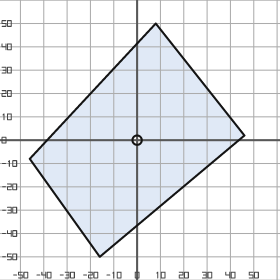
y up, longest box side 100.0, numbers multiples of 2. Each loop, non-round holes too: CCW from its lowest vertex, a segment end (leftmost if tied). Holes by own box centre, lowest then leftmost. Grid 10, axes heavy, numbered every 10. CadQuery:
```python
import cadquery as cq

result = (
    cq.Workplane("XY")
    .moveTo(-16.0, -50.0)
    .lineTo(46.0, 2.0)
    .lineTo(8.0, 50.0)
    .lineTo(-46.0, -8.0)
    .close()
    .moveTo(0.0, 0.0)
    .circle(2.0)
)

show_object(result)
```